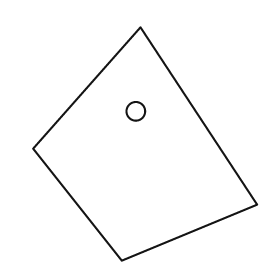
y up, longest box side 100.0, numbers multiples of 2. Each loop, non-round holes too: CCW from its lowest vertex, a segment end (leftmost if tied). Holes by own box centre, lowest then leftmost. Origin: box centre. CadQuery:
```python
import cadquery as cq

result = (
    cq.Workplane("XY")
    .moveTo(-10.0, -50.0)
    .lineTo(48.0, -26.0)
    .lineTo(-2.0, 50.0)
    .lineTo(-48.0, -2.0)
    .close()
    .moveTo(-4.0, 14.0)
    .circle(4.0)
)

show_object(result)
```